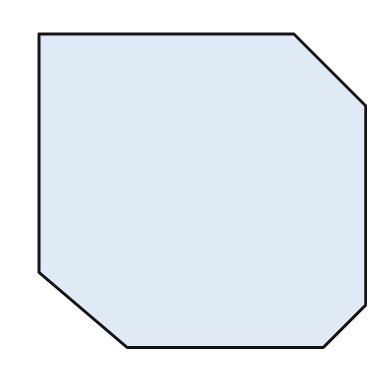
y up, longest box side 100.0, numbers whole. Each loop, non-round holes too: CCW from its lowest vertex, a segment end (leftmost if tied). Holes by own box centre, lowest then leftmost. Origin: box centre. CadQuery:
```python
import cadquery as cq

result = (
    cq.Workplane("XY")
    .moveTo(-23.0, -48.0)
    .lineTo(37.0, -48.0)
    .lineTo(50.0, -35.0)
    .lineTo(50.0, 26.0)
    .lineTo(28.0, 48.0)
    .lineTo(-50.0, 48.0)
    .lineTo(-50.0, -25.0)
    .close()
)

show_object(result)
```